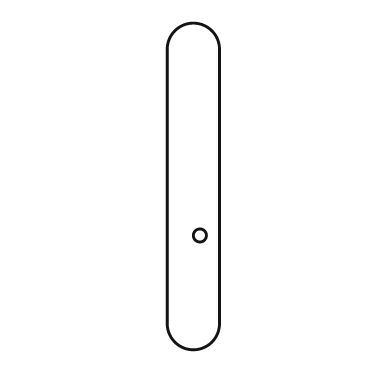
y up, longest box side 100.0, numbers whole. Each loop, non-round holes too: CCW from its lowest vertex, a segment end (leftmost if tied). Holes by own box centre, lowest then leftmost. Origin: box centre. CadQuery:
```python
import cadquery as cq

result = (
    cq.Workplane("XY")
    .moveTo(-8.0, -42.0)
    .threePointArc((0.0, -50.0), (8.0, -42.0))
    .lineTo(8.0, 42.0)
    .threePointArc((0.0, 50.0), (-8.0, 42.0))
    .close()
    .moveTo(2.0, -15.0)
    .circle(2.0)
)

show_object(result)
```